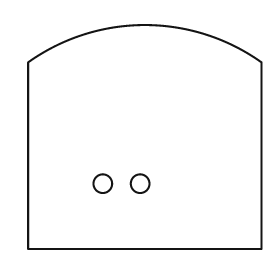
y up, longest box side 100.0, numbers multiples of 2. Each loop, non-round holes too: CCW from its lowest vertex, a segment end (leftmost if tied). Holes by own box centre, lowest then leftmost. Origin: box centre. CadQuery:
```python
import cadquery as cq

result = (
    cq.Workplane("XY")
    .moveTo(-50.0, -48.0)
    .lineTo(50.0, -48.0)
    .lineTo(50.0, 32.0)
    .threePointArc((0.0, 48.0), (-50.0, 32.0))
    .close()
    .moveTo(-18.0, -20.0)
    .circle(4.0)
    .moveTo(-2.0, -20.0)
    .circle(4.0)
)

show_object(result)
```